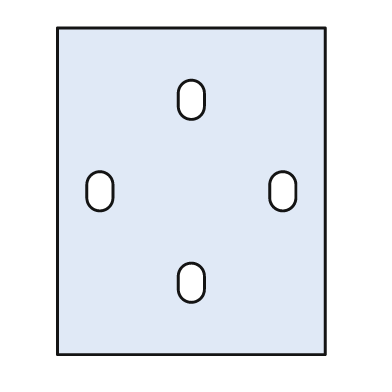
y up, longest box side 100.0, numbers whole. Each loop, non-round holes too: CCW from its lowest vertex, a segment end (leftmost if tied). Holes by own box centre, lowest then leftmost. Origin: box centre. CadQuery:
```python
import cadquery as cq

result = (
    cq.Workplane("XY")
    .moveTo(-41.0, -50.0)
    .lineTo(41.0, -50.0)
    .lineTo(41.0, 50.0)
    .lineTo(-41.0, 50.0)
    .close()
    .moveTo(-4.0, -30.0)
    .threePointArc((0.0, -34.0), (4.0, -30.0))
    .lineTo(4.0, -26.0)
    .threePointArc((0.0, -22.0), (-4.0, -26.0))
    .close()
    .moveTo(-32.0, -2.0)
    .threePointArc((-28.0, -6.0), (-24.0, -2.0))
    .lineTo(-24.0, 2.0)
    .threePointArc((-28.0, 6.0), (-32.0, 2.0))
    .close()
    .moveTo(24.0, -2.0)
    .threePointArc((28.0, -6.0), (32.0, -2.0))
    .lineTo(32.0, 2.0)
    .threePointArc((28.0, 6.0), (24.0, 2.0))
    .close()
    .moveTo(-4.0, 26.0)
    .threePointArc((0.0, 22.0), (4.0, 26.0))
    .lineTo(4.0, 30.0)
    .threePointArc((0.0, 34.0), (-4.0, 30.0))
    .close()
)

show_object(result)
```